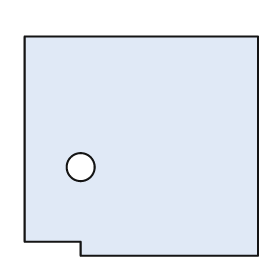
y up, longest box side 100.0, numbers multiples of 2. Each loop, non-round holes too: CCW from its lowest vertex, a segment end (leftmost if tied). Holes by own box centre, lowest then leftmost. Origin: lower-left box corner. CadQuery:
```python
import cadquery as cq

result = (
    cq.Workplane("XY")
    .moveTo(24.0, 0.0)
    .lineTo(100.0, 0.0)
    .lineTo(100.0, 94.0)
    .lineTo(0.0, 94.0)
    .lineTo(0.0, 6.0)
    .lineTo(24.0, 6.0)
    .close()
    .moveTo(24.0, 38.0)
    .circle(6.0)
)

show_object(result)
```